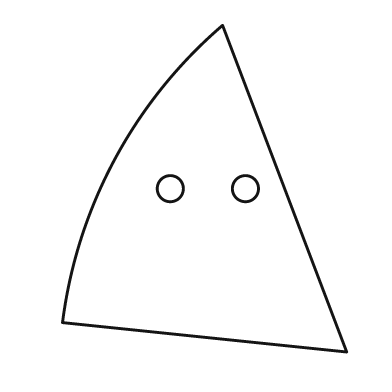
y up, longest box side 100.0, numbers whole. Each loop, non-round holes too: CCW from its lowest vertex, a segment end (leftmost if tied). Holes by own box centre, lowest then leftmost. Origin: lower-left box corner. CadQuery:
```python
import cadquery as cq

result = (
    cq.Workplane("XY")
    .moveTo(87.0, 0.0)
    .lineTo(49.0, 100.0)
    .threePointArc((16.0, 59.0), (0.0, 9.0))
    .close()
    .moveTo(33.0, 50.0)
    .circle(4.0)
    .moveTo(56.0, 50.0)
    .circle(4.0)
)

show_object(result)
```